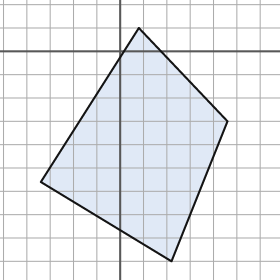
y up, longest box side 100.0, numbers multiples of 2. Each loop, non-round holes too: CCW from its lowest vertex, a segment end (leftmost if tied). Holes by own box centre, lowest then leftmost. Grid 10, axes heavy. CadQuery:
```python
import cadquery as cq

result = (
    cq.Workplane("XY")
    .moveTo(22.0, -90.0)
    .lineTo(46.0, -30.0)
    .lineTo(8.0, 10.0)
    .lineTo(-34.0, -56.0)
    .close()
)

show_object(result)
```